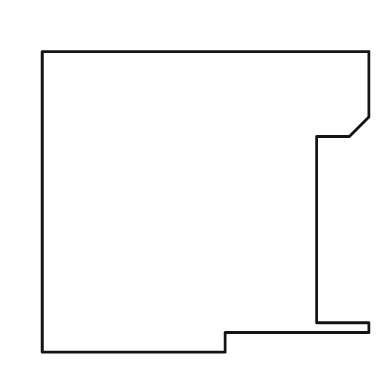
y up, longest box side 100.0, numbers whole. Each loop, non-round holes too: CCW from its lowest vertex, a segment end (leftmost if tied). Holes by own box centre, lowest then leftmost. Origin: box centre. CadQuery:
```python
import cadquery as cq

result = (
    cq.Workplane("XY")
    .moveTo(-50.0, -46.0)
    .lineTo(6.0, -46.0)
    .lineTo(6.0, -40.0)
    .lineTo(50.0, -40.0)
    .lineTo(50.0, -37.0)
    .lineTo(34.0, -37.0)
    .lineTo(34.0, 20.0)
    .lineTo(44.0, 20.0)
    .lineTo(50.0, 26.0)
    .lineTo(50.0, 46.0)
    .lineTo(-50.0, 46.0)
    .close()
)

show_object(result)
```